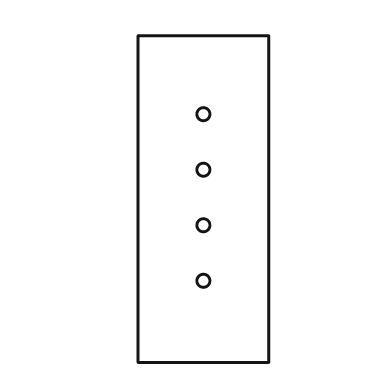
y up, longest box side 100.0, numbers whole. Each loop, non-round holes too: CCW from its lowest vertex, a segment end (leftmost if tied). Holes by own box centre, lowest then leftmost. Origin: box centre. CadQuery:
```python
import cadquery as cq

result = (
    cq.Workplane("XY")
    .moveTo(-20.0, -50.0)
    .lineTo(20.0, -50.0)
    .lineTo(20.0, 50.0)
    .lineTo(-20.0, 50.0)
    .close()
    .moveTo(0.0, -25.0)
    .circle(2.0)
    .moveTo(0.0, -8.0)
    .circle(2.0)
    .moveTo(0.0, 9.0)
    .circle(2.0)
    .moveTo(0.0, 26.0)
    .circle(2.0)
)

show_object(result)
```